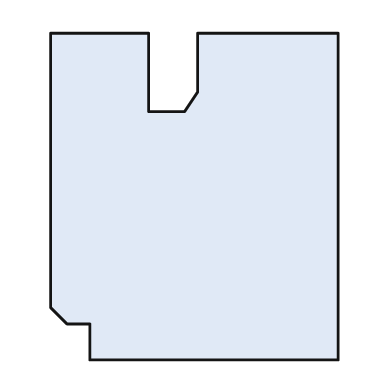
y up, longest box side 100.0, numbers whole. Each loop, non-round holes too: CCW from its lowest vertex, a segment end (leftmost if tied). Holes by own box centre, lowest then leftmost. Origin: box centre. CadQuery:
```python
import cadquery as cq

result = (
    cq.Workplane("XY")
    .moveTo(-32.0, -50.0)
    .lineTo(44.0, -50.0)
    .lineTo(44.0, 50.0)
    .lineTo(1.0, 50.0)
    .lineTo(1.0, 32.0)
    .lineTo(-3.0, 26.0)
    .lineTo(-14.0, 26.0)
    .lineTo(-14.0, 50.0)
    .lineTo(-44.0, 50.0)
    .lineTo(-44.0, -34.0)
    .lineTo(-39.0, -39.0)
    .lineTo(-32.0, -39.0)
    .close()
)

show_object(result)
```